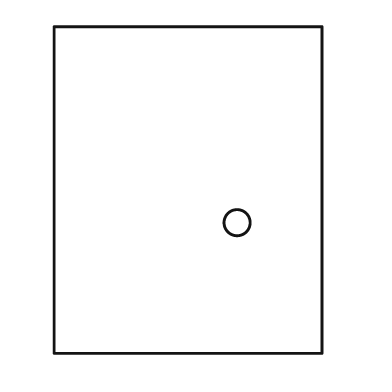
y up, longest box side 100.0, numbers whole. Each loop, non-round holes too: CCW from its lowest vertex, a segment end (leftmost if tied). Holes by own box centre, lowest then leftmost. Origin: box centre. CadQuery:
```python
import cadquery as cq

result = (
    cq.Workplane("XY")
    .moveTo(-41.0, -50.0)
    .lineTo(41.0, -50.0)
    .lineTo(41.0, 50.0)
    .lineTo(-41.0, 50.0)
    .close()
    .moveTo(15.0, -10.0)
    .circle(4.0)
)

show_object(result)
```